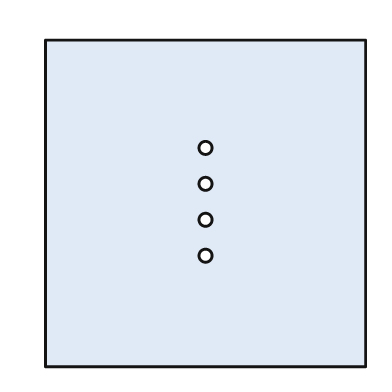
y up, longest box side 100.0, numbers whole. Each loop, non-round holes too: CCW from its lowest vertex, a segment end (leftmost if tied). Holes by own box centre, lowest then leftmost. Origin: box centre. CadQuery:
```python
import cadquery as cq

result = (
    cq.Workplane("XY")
    .moveTo(-49.0, -50.0)
    .lineTo(49.0, -50.0)
    .lineTo(49.0, 50.0)
    .lineTo(-49.0, 50.0)
    .close()
    .moveTo(0.0, -16.0)
    .circle(2.0)
    .moveTo(0.0, -5.0)
    .circle(2.0)
    .moveTo(0.0, 6.0)
    .circle(2.0)
    .moveTo(0.0, 17.0)
    .circle(2.0)
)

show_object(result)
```